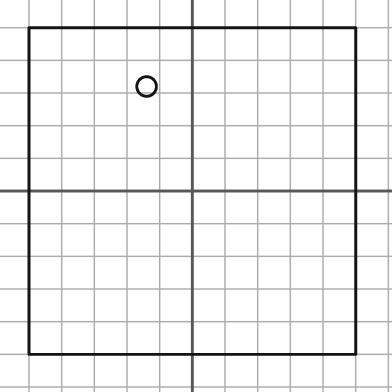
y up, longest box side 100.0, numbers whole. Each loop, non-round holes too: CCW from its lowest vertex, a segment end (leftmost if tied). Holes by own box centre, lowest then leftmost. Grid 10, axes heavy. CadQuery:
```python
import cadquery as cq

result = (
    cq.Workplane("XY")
    .moveTo(-50.0, -50.0)
    .lineTo(50.0, -50.0)
    .lineTo(50.0, 50.0)
    .lineTo(-50.0, 50.0)
    .close()
    .moveTo(-14.0, 32.0)
    .circle(3.0)
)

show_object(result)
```